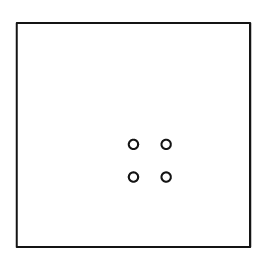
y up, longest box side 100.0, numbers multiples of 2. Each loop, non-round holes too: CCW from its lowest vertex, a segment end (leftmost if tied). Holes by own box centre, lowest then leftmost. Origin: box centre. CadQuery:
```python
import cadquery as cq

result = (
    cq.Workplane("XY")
    .moveTo(-50.0, -48.0)
    .lineTo(50.0, -48.0)
    .lineTo(50.0, 48.0)
    .lineTo(-50.0, 48.0)
    .close()
    .moveTo(0.0, -18.0)
    .circle(2.0)
    .moveTo(14.0, -18.0)
    .circle(2.0)
    .moveTo(0.0, -4.0)
    .circle(2.0)
    .moveTo(14.0, -4.0)
    .circle(2.0)
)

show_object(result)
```